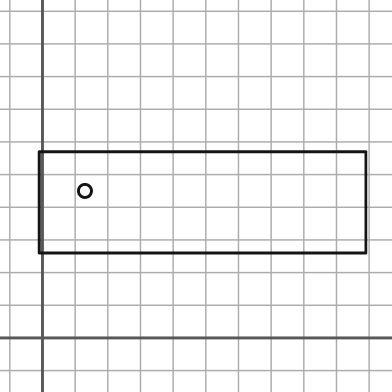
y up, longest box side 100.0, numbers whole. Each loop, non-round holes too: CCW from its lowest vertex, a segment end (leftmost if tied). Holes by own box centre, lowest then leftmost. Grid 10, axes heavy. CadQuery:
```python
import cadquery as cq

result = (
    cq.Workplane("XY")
    .moveTo(-1.0, 26.0)
    .lineTo(99.0, 26.0)
    .lineTo(99.0, 57.0)
    .lineTo(-1.0, 57.0)
    .close()
    .moveTo(13.0, 45.0)
    .circle(2.0)
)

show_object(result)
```